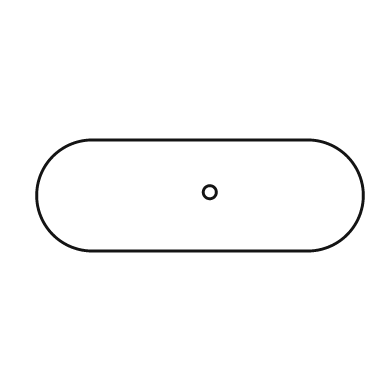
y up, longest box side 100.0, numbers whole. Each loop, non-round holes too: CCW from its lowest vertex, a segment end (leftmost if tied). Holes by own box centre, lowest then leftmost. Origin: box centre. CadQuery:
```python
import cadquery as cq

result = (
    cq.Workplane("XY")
    .moveTo(-33.0, -17.0)
    .lineTo(33.0, -17.0)
    .threePointArc((50.0, 0.0), (33.0, 17.0))
    .lineTo(-33.0, 17.0)
    .threePointArc((-50.0, 0.0), (-33.0, -17.0))
    .close()
    .moveTo(3.0, 1.0)
    .circle(2.0)
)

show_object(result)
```